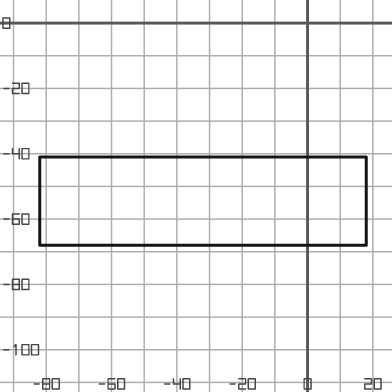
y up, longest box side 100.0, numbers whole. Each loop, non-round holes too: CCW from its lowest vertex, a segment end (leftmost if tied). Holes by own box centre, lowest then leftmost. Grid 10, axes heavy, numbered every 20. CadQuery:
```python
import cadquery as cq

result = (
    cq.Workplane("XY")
    .moveTo(-82.0, -68.0)
    .lineTo(18.0, -68.0)
    .lineTo(18.0, -41.0)
    .lineTo(-82.0, -41.0)
    .close()
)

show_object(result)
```